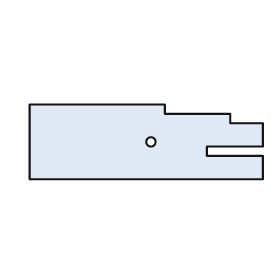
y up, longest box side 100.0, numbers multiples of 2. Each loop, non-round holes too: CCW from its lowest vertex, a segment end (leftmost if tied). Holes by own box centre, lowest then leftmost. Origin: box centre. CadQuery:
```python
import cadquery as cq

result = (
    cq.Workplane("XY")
    .moveTo(-50.0, -16.0)
    .lineTo(50.0, -16.0)
    .lineTo(50.0, -6.0)
    .lineTo(26.0, -6.0)
    .lineTo(26.0, -2.0)
    .lineTo(50.0, -2.0)
    .lineTo(50.0, 8.0)
    .lineTo(36.0, 8.0)
    .lineTo(36.0, 12.0)
    .lineTo(8.0, 12.0)
    .lineTo(8.0, 16.0)
    .lineTo(-50.0, 16.0)
    .close()
    .moveTo(2.0, 0.0)
    .circle(2.0)
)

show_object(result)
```